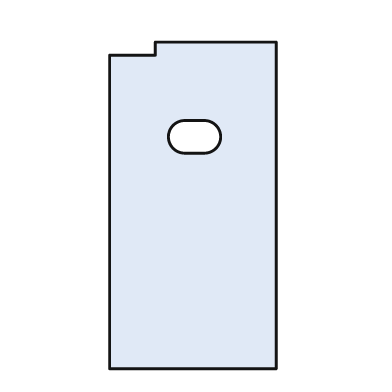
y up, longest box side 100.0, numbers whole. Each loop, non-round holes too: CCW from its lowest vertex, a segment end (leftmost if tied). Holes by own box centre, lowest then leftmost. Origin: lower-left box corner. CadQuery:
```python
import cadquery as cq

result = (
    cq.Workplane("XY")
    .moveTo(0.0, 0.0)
    .lineTo(51.0, 0.0)
    .lineTo(51.0, 100.0)
    .lineTo(14.0, 100.0)
    .lineTo(14.0, 96.0)
    .lineTo(0.0, 96.0)
    .close()
    .moveTo(23.0, 66.0)
    .lineTo(29.0, 66.0)
    .threePointArc((34.0, 71.0), (29.0, 76.0))
    .lineTo(23.0, 76.0)
    .threePointArc((18.0, 71.0), (23.0, 66.0))
    .close()
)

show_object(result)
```